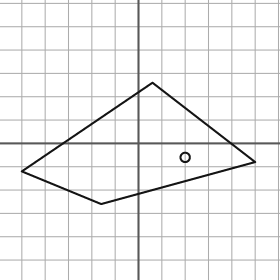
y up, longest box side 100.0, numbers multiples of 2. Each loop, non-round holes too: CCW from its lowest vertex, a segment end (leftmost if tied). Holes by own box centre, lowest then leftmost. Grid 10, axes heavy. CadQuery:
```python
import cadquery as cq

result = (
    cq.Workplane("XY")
    .moveTo(-16.0, -26.0)
    .lineTo(50.0, -8.0)
    .lineTo(6.0, 26.0)
    .lineTo(-50.0, -12.0)
    .close()
    .moveTo(20.0, -6.0)
    .circle(2.0)
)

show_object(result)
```